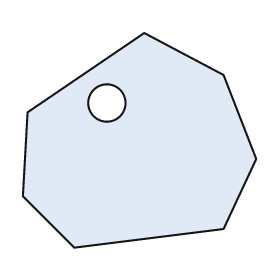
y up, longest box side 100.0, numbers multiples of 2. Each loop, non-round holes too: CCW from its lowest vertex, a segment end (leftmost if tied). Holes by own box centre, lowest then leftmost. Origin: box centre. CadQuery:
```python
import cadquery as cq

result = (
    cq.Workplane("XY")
    .moveTo(-28.0, -46.0)
    .lineTo(36.0, -38.0)
    .lineTo(50.0, -8.0)
    .lineTo(36.0, 28.0)
    .lineTo(2.0, 46.0)
    .lineTo(-48.0, 12.0)
    .lineTo(-50.0, -24.0)
    .close()
    .moveTo(-14.0, 16.0)
    .circle(8.0)
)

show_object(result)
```